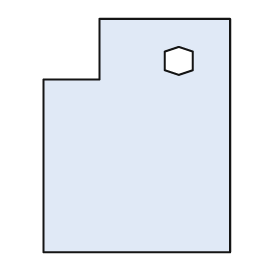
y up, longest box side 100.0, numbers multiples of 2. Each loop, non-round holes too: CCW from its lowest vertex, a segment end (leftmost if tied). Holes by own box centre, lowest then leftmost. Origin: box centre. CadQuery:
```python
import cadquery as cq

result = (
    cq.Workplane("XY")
    .moveTo(-40.0, -50.0)
    .lineTo(40.0, -50.0)
    .lineTo(40.0, 50.0)
    .lineTo(-16.0, 50.0)
    .lineTo(-16.0, 24.0)
    .lineTo(-40.0, 24.0)
    .close()
    .moveTo(18.0, 26.0)
    .lineTo(24.0, 28.0)
    .lineTo(24.0, 36.0)
    .lineTo(18.0, 38.0)
    .lineTo(12.0, 36.0)
    .lineTo(12.0, 28.0)
    .close()
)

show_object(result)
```